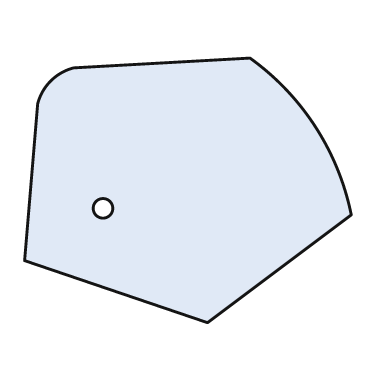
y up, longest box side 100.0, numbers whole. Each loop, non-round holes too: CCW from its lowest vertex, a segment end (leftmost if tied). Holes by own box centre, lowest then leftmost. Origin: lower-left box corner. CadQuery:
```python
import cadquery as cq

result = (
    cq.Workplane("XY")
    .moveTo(56.0, 0.0)
    .lineTo(100.0, 33.0)
    .threePointArc((89.0, 60.0), (69.0, 81.0))
    .lineTo(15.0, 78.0)
    .threePointArc((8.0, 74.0), (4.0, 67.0))
    .lineTo(0.0, 19.0)
    .close()
    .moveTo(24.0, 35.0)
    .circle(3.0)
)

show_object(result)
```